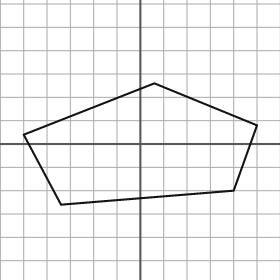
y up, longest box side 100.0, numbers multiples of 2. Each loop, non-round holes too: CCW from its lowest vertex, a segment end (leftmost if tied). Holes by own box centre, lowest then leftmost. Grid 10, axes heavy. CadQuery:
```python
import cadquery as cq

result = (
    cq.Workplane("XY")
    .moveTo(-34.0, -26.0)
    .lineTo(40.0, -20.0)
    .lineTo(50.0, 8.0)
    .lineTo(6.0, 26.0)
    .lineTo(-50.0, 4.0)
    .close()
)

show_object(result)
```